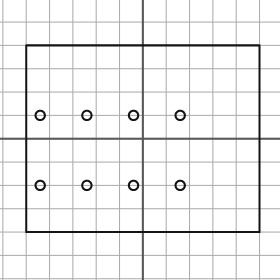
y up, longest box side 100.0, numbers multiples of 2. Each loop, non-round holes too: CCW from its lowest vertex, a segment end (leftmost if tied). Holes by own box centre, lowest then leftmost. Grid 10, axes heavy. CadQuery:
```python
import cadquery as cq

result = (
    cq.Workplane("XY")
    .moveTo(-50.0, -40.0)
    .lineTo(50.0, -40.0)
    .lineTo(50.0, 40.0)
    .lineTo(-50.0, 40.0)
    .close()
    .moveTo(-44.0, -20.0)
    .circle(2.0)
    .moveTo(-24.0, -20.0)
    .circle(2.0)
    .moveTo(-4.0, -20.0)
    .circle(2.0)
    .moveTo(16.0, -20.0)
    .circle(2.0)
    .moveTo(-44.0, 10.0)
    .circle(2.0)
    .moveTo(-24.0, 10.0)
    .circle(2.0)
    .moveTo(-4.0, 10.0)
    .circle(2.0)
    .moveTo(16.0, 10.0)
    .circle(2.0)
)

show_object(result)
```